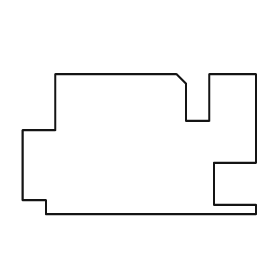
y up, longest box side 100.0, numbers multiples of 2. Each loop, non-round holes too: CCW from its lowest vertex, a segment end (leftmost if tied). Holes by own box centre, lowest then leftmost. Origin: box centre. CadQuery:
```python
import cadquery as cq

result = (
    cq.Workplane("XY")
    .moveTo(-40.0, -30.0)
    .lineTo(50.0, -30.0)
    .lineTo(50.0, -26.0)
    .lineTo(32.0, -26.0)
    .lineTo(32.0, -8.0)
    .lineTo(50.0, -8.0)
    .lineTo(50.0, 30.0)
    .lineTo(30.0, 30.0)
    .lineTo(30.0, 10.0)
    .lineTo(20.0, 10.0)
    .lineTo(20.0, 26.0)
    .lineTo(16.0, 30.0)
    .lineTo(-36.0, 30.0)
    .lineTo(-36.0, 6.0)
    .lineTo(-50.0, 6.0)
    .lineTo(-50.0, -24.0)
    .lineTo(-40.0, -24.0)
    .close()
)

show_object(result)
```